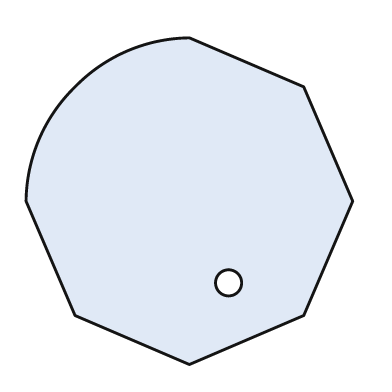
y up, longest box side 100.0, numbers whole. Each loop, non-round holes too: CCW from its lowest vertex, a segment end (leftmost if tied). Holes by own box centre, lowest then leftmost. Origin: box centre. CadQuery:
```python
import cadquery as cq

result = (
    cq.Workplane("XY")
    .moveTo(0.0, -50.0)
    .lineTo(35.0, -35.0)
    .lineTo(50.0, 0.0)
    .lineTo(35.0, 35.0)
    .lineTo(0.0, 50.0)
    .threePointArc((-19.0, 46.0), (-35.0, 35.0))
    .threePointArc((-46.0, 19.0), (-50.0, 0.0))
    .lineTo(-35.0, -35.0)
    .close()
    .moveTo(12.0, -25.0)
    .circle(4.0)
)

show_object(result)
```